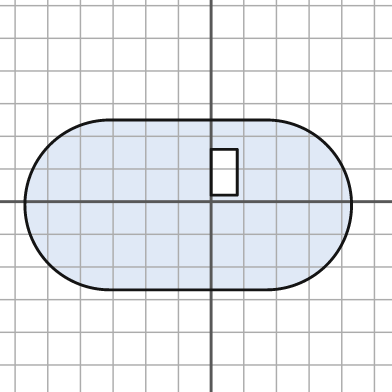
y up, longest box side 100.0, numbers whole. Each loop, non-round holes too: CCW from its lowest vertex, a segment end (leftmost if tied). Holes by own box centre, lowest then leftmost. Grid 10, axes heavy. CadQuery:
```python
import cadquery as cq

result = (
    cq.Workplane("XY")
    .moveTo(-31.0, -27.0)
    .lineTo(17.0, -27.0)
    .threePointArc((43.0, -1.0), (17.0, 25.0))
    .lineTo(-31.0, 25.0)
    .threePointArc((-57.0, -1.0), (-31.0, -27.0))
    .close()
    .moveTo(0.0, 2.0)
    .lineTo(8.0, 2.0)
    .lineTo(8.0, 16.0)
    .lineTo(0.0, 16.0)
    .close()
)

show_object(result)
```